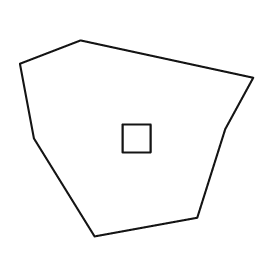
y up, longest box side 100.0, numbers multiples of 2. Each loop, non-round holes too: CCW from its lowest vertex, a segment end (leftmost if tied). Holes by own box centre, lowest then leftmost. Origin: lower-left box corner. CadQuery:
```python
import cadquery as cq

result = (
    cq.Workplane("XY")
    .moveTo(32.0, 0.0)
    .lineTo(76.0, 8.0)
    .lineTo(88.0, 46.0)
    .lineTo(100.0, 68.0)
    .lineTo(26.0, 84.0)
    .lineTo(0.0, 74.0)
    .lineTo(6.0, 42.0)
    .close()
    .moveTo(44.0, 36.0)
    .lineTo(56.0, 36.0)
    .lineTo(56.0, 48.0)
    .lineTo(44.0, 48.0)
    .close()
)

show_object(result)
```